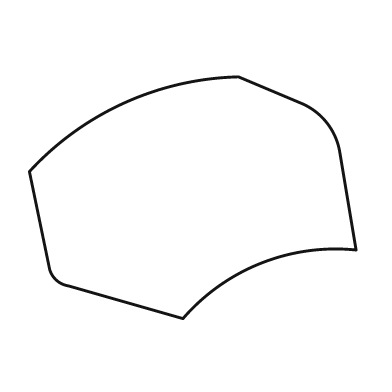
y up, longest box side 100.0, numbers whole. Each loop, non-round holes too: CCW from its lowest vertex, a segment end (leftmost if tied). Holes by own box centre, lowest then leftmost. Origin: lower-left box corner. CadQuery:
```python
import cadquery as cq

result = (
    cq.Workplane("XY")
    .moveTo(47.0, 0.0)
    .threePointArc((71.0, 17.0), (100.0, 21.0))
    .lineTo(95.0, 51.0)
    .threePointArc((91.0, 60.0), (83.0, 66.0))
    .lineTo(64.0, 74.0)
    .threePointArc((29.0, 66.0), (0.0, 45.0))
    .lineTo(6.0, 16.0)
    .threePointArc((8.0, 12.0), (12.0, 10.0))
    .close()
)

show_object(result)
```